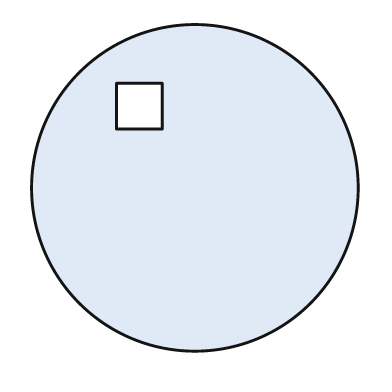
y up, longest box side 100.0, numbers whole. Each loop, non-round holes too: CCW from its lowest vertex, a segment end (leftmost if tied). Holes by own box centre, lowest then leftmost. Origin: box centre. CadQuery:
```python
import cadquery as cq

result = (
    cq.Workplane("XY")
    .moveTo(0.0, 0.0)
    .circle(50.0)
    .moveTo(-24.0, 18.0)
    .lineTo(-10.0, 18.0)
    .lineTo(-10.0, 32.0)
    .lineTo(-24.0, 32.0)
    .close()
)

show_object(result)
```